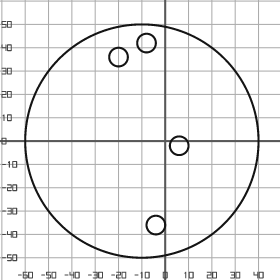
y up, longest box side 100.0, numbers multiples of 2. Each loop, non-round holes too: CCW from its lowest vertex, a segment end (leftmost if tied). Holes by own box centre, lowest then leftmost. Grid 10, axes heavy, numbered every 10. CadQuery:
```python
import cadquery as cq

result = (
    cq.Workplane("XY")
    .moveTo(-10.0, 0.0)
    .circle(50.0)
    .moveTo(-4.0, -36.0)
    .circle(4.0)
    .moveTo(6.0, -2.0)
    .circle(4.0)
    .moveTo(-20.0, 36.0)
    .circle(4.0)
    .moveTo(-8.0, 42.0)
    .circle(4.0)
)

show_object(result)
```